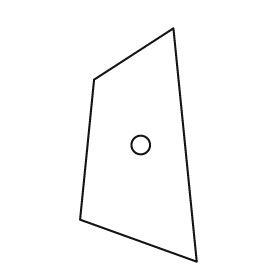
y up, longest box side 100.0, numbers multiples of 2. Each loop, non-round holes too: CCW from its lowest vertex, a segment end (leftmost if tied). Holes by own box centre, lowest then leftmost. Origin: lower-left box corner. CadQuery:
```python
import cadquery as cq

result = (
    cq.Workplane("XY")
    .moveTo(50.0, 0.0)
    .lineTo(40.0, 100.0)
    .lineTo(6.0, 78.0)
    .lineTo(0.0, 18.0)
    .close()
    .moveTo(26.0, 50.0)
    .circle(4.0)
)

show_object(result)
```